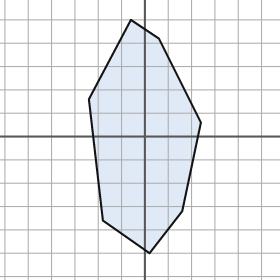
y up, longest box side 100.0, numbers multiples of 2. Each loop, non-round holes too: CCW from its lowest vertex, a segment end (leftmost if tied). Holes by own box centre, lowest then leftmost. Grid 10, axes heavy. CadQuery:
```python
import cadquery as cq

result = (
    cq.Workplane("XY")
    .moveTo(2.0, -50.0)
    .lineTo(16.0, -32.0)
    .lineTo(24.0, 6.0)
    .lineTo(6.0, 42.0)
    .lineTo(-6.0, 50.0)
    .lineTo(-24.0, 16.0)
    .lineTo(-18.0, -36.0)
    .close()
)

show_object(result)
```